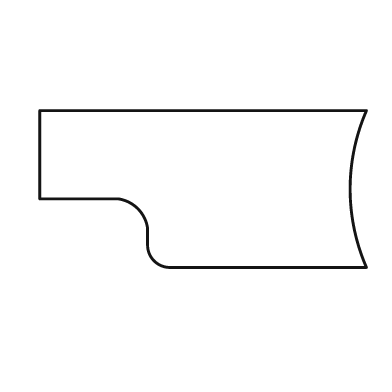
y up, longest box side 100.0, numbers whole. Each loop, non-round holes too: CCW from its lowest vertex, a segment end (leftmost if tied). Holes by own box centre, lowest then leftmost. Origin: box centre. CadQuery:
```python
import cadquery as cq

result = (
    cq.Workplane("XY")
    .moveTo(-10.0, -24.0)
    .lineTo(50.0, -24.0)
    .threePointArc((45.0, 0.0), (50.0, 24.0))
    .lineTo(-50.0, 24.0)
    .lineTo(-50.0, -3.0)
    .lineTo(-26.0, -3.0)
    .threePointArc((-20.0, -6.0), (-17.0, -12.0))
    .lineTo(-17.0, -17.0)
    .threePointArc((-15.0, -22.0), (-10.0, -24.0))
    .close()
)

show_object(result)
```